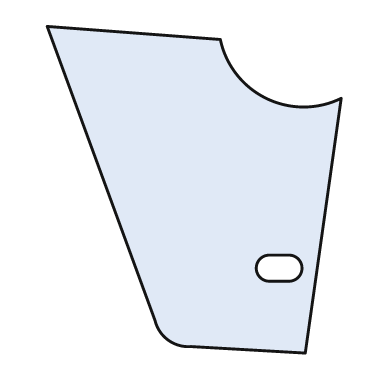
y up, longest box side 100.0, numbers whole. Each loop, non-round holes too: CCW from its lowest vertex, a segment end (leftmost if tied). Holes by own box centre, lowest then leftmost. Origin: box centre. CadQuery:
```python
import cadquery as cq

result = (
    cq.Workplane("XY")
    .moveTo(34.0, -50.0)
    .lineTo(45.0, 28.0)
    .threePointArc((22.0, 28.0), (8.0, 46.0))
    .lineTo(-45.0, 50.0)
    .lineTo(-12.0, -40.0)
    .threePointArc((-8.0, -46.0), (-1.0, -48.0))
    .close()
    .moveTo(23.0, -28.0)
    .lineTo(29.0, -28.0)
    .threePointArc((33.0, -24.0), (29.0, -20.0))
    .lineTo(23.0, -20.0)
    .threePointArc((19.0, -24.0), (23.0, -28.0))
    .close()
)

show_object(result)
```